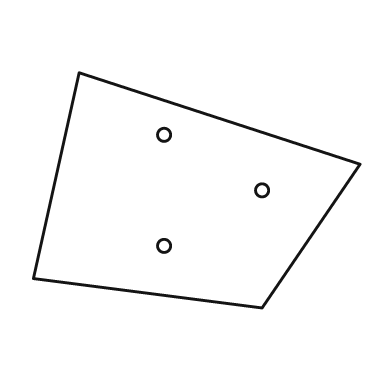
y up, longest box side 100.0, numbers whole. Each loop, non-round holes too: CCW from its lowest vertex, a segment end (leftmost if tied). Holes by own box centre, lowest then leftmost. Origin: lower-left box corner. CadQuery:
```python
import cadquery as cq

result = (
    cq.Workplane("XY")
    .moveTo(70.0, 0.0)
    .lineTo(100.0, 44.0)
    .lineTo(14.0, 72.0)
    .lineTo(0.0, 9.0)
    .close()
    .moveTo(40.0, 19.0)
    .circle(2.0)
    .moveTo(70.0, 36.0)
    .circle(2.0)
    .moveTo(40.0, 53.0)
    .circle(2.0)
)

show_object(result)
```